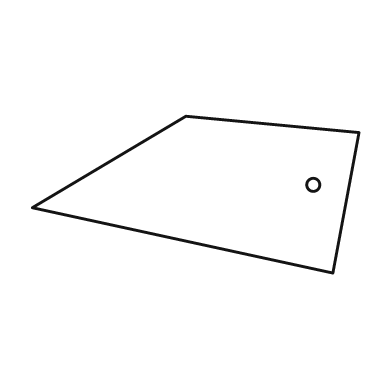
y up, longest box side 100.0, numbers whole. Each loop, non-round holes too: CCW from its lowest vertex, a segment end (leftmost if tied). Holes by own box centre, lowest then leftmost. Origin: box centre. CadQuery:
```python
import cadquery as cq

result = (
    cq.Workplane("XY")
    .moveTo(42.0, -24.0)
    .lineTo(50.0, 19.0)
    .lineTo(-3.0, 24.0)
    .lineTo(-50.0, -4.0)
    .close()
    .moveTo(36.0, 3.0)
    .circle(2.0)
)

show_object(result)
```